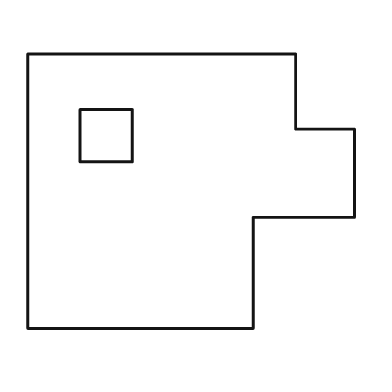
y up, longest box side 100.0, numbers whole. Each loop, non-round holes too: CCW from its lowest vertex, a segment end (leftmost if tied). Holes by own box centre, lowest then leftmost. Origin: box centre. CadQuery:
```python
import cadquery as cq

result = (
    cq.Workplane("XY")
    .moveTo(-50.0, -42.0)
    .lineTo(19.0, -42.0)
    .lineTo(19.0, -8.0)
    .lineTo(50.0, -8.0)
    .lineTo(50.0, 19.0)
    .lineTo(32.0, 19.0)
    .lineTo(32.0, 42.0)
    .lineTo(-50.0, 42.0)
    .close()
    .moveTo(-34.0, 9.0)
    .lineTo(-18.0, 9.0)
    .lineTo(-18.0, 25.0)
    .lineTo(-34.0, 25.0)
    .close()
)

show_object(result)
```